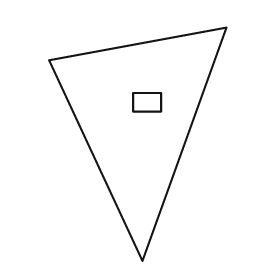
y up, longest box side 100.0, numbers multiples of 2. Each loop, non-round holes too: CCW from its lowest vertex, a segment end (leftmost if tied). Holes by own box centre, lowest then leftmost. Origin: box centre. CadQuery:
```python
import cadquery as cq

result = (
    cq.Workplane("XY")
    .moveTo(2.0, -50.0)
    .lineTo(38.0, 50.0)
    .lineTo(-38.0, 36.0)
    .close()
    .moveTo(-2.0, 14.0)
    .lineTo(10.0, 14.0)
    .lineTo(10.0, 22.0)
    .lineTo(-2.0, 22.0)
    .close()
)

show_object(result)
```